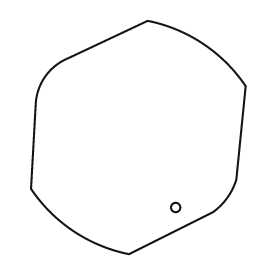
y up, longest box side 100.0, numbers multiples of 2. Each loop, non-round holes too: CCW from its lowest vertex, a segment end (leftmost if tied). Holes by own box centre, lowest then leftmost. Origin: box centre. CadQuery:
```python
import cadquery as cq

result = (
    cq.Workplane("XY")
    .moveTo(-4.0, -50.0)
    .lineTo(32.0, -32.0)
    .threePointArc((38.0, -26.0), (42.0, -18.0))
    .lineTo(46.0, 22.0)
    .threePointArc((28.0, 40.0), (4.0, 50.0))
    .lineTo(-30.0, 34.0)
    .threePointArc((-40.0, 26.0), (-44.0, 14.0))
    .lineTo(-46.0, -22.0)
    .threePointArc((-28.0, -40.0), (-4.0, -50.0))
    .close()
    .moveTo(16.0, -30.0)
    .circle(2.0)
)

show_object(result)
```